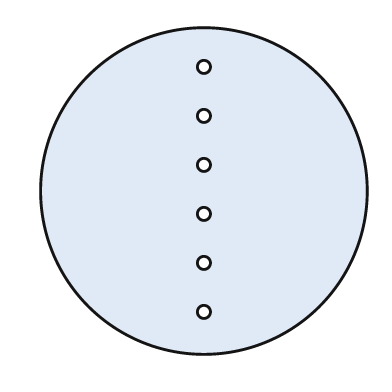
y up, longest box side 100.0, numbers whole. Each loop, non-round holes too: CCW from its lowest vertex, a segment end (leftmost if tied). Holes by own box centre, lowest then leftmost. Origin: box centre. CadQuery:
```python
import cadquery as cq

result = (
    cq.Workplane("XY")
    .moveTo(0.0, 0.0)
    .circle(50.0)
    .moveTo(0.0, -37.0)
    .circle(2.0)
    .moveTo(0.0, -22.0)
    .circle(2.0)
    .moveTo(0.0, -7.0)
    .circle(2.0)
    .moveTo(0.0, 8.0)
    .circle(2.0)
    .moveTo(0.0, 23.0)
    .circle(2.0)
    .moveTo(0.0, 38.0)
    .circle(2.0)
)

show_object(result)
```